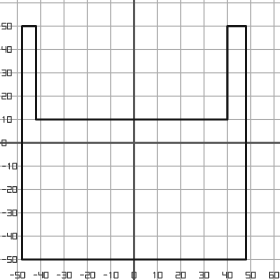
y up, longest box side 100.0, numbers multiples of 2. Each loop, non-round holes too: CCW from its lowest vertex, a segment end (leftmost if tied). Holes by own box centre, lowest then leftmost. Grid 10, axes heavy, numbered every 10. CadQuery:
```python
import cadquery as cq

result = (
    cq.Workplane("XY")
    .moveTo(-48.0, -50.0)
    .lineTo(48.0, -50.0)
    .lineTo(48.0, 50.0)
    .lineTo(40.0, 50.0)
    .lineTo(40.0, 10.0)
    .lineTo(-42.0, 10.0)
    .lineTo(-42.0, 50.0)
    .lineTo(-48.0, 50.0)
    .close()
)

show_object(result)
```